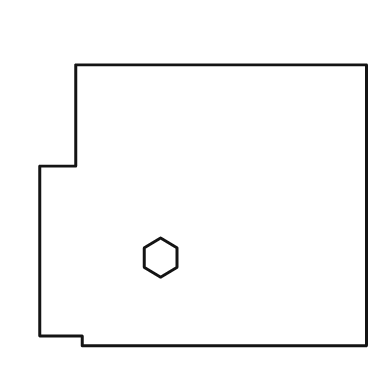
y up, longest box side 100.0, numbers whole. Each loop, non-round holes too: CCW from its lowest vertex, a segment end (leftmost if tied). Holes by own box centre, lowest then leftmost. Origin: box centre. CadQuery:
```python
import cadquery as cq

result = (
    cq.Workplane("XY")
    .moveTo(-37.0, -43.0)
    .lineTo(50.0, -43.0)
    .lineTo(50.0, 43.0)
    .lineTo(-39.0, 43.0)
    .lineTo(-39.0, 12.0)
    .lineTo(-50.0, 12.0)
    .lineTo(-50.0, -40.0)
    .lineTo(-37.0, -40.0)
    .close()
    .moveTo(-13.0, -22.0)
    .lineTo(-8.0, -19.0)
    .lineTo(-8.0, -13.0)
    .lineTo(-13.0, -10.0)
    .lineTo(-18.0, -13.0)
    .lineTo(-18.0, -19.0)
    .close()
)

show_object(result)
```